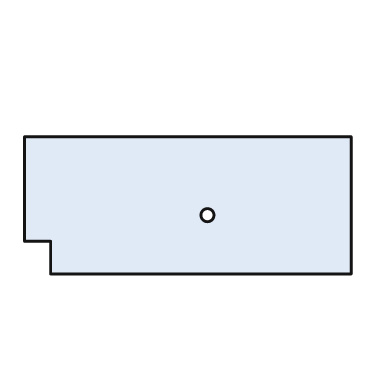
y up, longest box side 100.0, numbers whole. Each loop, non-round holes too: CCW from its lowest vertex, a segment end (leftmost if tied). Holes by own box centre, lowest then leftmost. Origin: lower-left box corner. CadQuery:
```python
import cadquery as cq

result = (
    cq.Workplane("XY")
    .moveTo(8.0, 0.0)
    .lineTo(100.0, 0.0)
    .lineTo(100.0, 42.0)
    .lineTo(0.0, 42.0)
    .lineTo(0.0, 10.0)
    .lineTo(8.0, 10.0)
    .close()
    .moveTo(56.0, 18.0)
    .circle(2.0)
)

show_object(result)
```